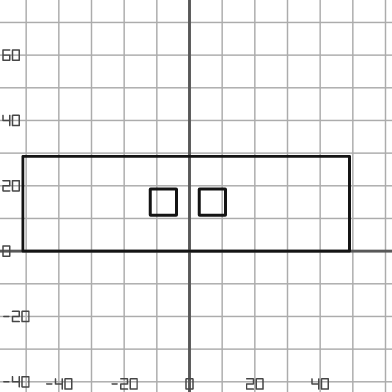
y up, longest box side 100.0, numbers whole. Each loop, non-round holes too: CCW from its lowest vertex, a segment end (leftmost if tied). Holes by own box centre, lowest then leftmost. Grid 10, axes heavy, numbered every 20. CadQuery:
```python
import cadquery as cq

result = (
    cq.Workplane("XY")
    .moveTo(-51.0, 0.0)
    .lineTo(49.0, 0.0)
    .lineTo(49.0, 29.0)
    .lineTo(-51.0, 29.0)
    .close()
    .moveTo(-12.0, 11.0)
    .lineTo(-4.0, 11.0)
    .lineTo(-4.0, 19.0)
    .lineTo(-12.0, 19.0)
    .close()
    .moveTo(3.0, 11.0)
    .lineTo(11.0, 11.0)
    .lineTo(11.0, 19.0)
    .lineTo(3.0, 19.0)
    .close()
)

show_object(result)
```